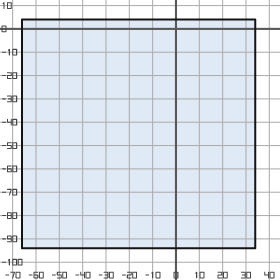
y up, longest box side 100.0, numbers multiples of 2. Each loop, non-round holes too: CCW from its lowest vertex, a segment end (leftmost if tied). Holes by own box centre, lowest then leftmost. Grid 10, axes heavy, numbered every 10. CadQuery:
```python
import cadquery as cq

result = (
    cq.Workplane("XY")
    .moveTo(-66.0, -94.0)
    .lineTo(34.0, -94.0)
    .lineTo(34.0, 4.0)
    .lineTo(-66.0, 4.0)
    .close()
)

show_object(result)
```